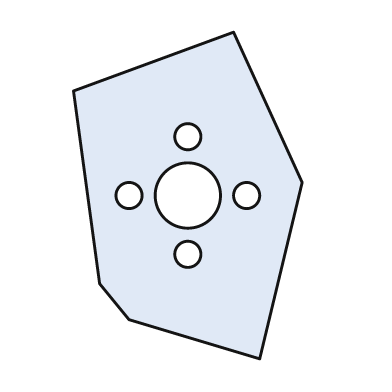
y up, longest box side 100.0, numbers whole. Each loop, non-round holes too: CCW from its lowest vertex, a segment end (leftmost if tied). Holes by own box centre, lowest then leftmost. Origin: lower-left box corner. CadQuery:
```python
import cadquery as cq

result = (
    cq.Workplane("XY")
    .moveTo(57.0, 0.0)
    .lineTo(70.0, 54.0)
    .lineTo(49.0, 100.0)
    .lineTo(0.0, 82.0)
    .lineTo(8.0, 23.0)
    .lineTo(17.0, 12.0)
    .close()
    .moveTo(35.0, 32.0)
    .circle(4.0)
    .moveTo(17.0, 50.0)
    .circle(4.0)
    .moveTo(35.0, 50.0)
    .circle(10.0)
    .moveTo(53.0, 50.0)
    .circle(4.0)
    .moveTo(35.0, 68.0)
    .circle(4.0)
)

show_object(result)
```